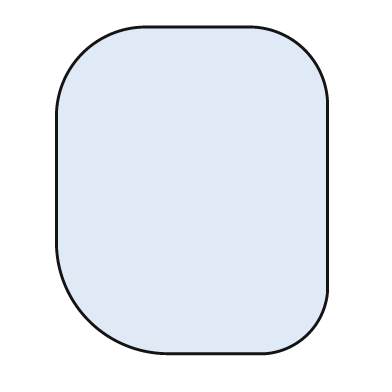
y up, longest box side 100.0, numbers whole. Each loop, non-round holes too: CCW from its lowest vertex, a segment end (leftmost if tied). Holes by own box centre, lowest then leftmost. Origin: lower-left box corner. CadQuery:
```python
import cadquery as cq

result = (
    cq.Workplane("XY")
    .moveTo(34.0, 0.0)
    .lineTo(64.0, 0.0)
    .threePointArc((77.0, 6.0), (83.0, 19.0))
    .lineTo(83.0, 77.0)
    .threePointArc((76.0, 93.0), (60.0, 100.0))
    .lineTo(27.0, 100.0)
    .threePointArc((8.0, 92.0), (0.0, 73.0))
    .lineTo(0.0, 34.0)
    .threePointArc((10.0, 10.0), (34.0, 0.0))
    .close()
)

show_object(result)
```